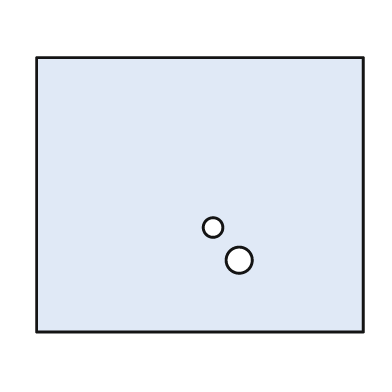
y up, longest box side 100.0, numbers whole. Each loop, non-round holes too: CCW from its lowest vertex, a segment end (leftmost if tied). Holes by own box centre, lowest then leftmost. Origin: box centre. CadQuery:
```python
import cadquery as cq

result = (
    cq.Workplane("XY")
    .moveTo(-50.0, -42.0)
    .lineTo(50.0, -42.0)
    .lineTo(50.0, 42.0)
    .lineTo(-50.0, 42.0)
    .close()
    .moveTo(12.0, -20.0)
    .circle(4.0)
    .moveTo(4.0, -10.0)
    .circle(3.0)
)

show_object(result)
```